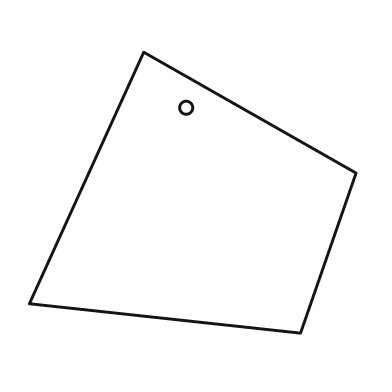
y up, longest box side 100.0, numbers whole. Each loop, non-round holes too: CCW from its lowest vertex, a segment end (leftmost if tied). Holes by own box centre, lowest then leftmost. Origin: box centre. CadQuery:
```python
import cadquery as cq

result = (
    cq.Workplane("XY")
    .moveTo(33.0, -43.0)
    .lineTo(50.0, 6.0)
    .lineTo(-15.0, 43.0)
    .lineTo(-50.0, -34.0)
    .close()
    .moveTo(-2.0, 26.0)
    .circle(2.0)
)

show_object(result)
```